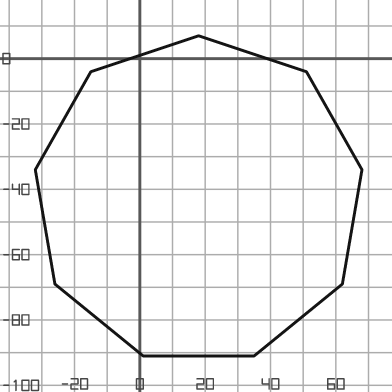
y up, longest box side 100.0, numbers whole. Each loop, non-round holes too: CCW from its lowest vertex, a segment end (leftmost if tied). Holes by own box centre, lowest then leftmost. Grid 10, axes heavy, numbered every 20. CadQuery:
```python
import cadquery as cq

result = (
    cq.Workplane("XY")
    .moveTo(1.0, -91.0)
    .lineTo(35.0, -91.0)
    .lineTo(62.0, -69.0)
    .lineTo(68.0, -34.0)
    .lineTo(51.0, -4.0)
    .lineTo(18.0, 7.0)
    .lineTo(-15.0, -4.0)
    .lineTo(-32.0, -34.0)
    .lineTo(-26.0, -69.0)
    .close()
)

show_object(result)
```